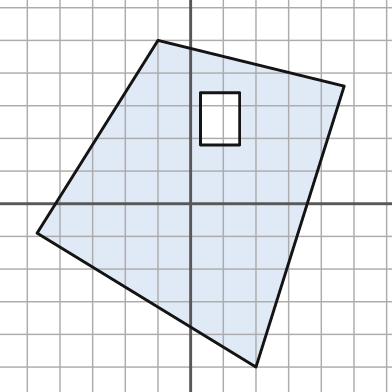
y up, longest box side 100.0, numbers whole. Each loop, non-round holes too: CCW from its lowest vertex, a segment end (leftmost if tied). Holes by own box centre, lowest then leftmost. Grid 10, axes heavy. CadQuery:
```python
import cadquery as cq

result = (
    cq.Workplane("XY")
    .moveTo(20.0, -50.0)
    .lineTo(47.0, 36.0)
    .lineTo(-10.0, 50.0)
    .lineTo(-47.0, -9.0)
    .close()
    .moveTo(3.0, 18.0)
    .lineTo(15.0, 18.0)
    .lineTo(15.0, 34.0)
    .lineTo(3.0, 34.0)
    .close()
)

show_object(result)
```